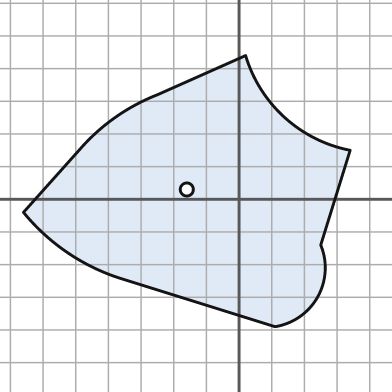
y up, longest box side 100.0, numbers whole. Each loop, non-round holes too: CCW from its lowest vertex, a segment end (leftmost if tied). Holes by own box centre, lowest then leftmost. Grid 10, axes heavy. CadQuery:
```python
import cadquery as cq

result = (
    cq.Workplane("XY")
    .moveTo(11.0, -39.0)
    .threePointArc((24.0, -30.0), (25.0, -14.0))
    .lineTo(34.0, 15.0)
    .threePointArc((14.0, 25.0), (2.0, 44.0))
    .lineTo(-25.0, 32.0)
    .threePointArc((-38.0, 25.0), (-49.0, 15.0))
    .lineTo(-66.0, -4.0)
    .threePointArc((-53.0, -16.0), (-37.0, -24.0))
    .close()
    .moveTo(-16.0, 3.0)
    .circle(2.0)
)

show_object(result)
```